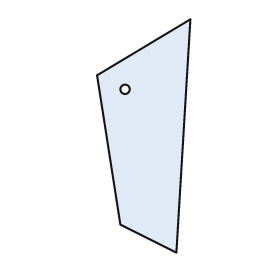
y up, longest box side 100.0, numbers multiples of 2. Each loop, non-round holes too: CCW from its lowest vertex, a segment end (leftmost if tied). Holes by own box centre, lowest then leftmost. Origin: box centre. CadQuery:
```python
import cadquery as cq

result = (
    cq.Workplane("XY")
    .moveTo(14.0, -50.0)
    .lineTo(20.0, 50.0)
    .lineTo(-20.0, 26.0)
    .lineTo(-10.0, -38.0)
    .close()
    .moveTo(-8.0, 20.0)
    .circle(2.0)
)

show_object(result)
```